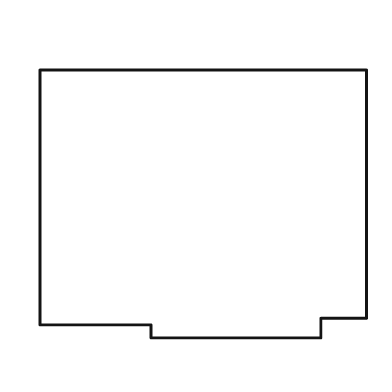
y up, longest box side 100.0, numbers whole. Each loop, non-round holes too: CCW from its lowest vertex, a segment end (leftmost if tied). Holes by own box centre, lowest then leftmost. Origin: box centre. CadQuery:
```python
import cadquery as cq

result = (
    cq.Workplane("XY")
    .moveTo(-16.0, -41.0)
    .lineTo(36.0, -41.0)
    .lineTo(36.0, -35.0)
    .lineTo(50.0, -35.0)
    .lineTo(50.0, 41.0)
    .lineTo(-50.0, 41.0)
    .lineTo(-50.0, -37.0)
    .lineTo(-16.0, -37.0)
    .close()
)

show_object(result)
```